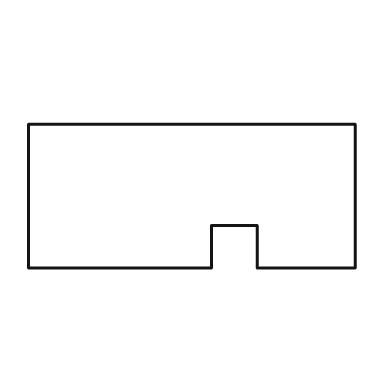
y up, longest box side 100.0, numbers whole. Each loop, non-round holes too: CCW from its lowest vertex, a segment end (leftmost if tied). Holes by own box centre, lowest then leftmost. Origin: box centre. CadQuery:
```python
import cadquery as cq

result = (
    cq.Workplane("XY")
    .moveTo(-50.0, -22.0)
    .lineTo(6.0, -22.0)
    .lineTo(6.0, -9.0)
    .lineTo(20.0, -9.0)
    .lineTo(20.0, -22.0)
    .lineTo(50.0, -22.0)
    .lineTo(50.0, 22.0)
    .lineTo(-50.0, 22.0)
    .close()
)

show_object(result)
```